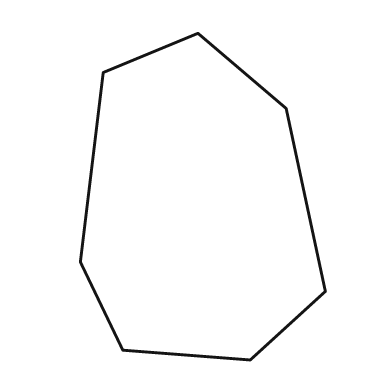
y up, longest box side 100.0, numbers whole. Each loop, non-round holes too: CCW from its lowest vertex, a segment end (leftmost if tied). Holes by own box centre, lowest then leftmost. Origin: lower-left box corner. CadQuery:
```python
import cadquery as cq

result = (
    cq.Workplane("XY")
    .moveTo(52.0, 0.0)
    .lineTo(75.0, 21.0)
    .lineTo(63.0, 77.0)
    .lineTo(36.0, 100.0)
    .lineTo(7.0, 88.0)
    .lineTo(0.0, 30.0)
    .lineTo(13.0, 3.0)
    .close()
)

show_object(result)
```